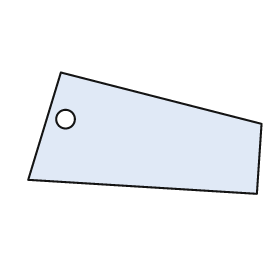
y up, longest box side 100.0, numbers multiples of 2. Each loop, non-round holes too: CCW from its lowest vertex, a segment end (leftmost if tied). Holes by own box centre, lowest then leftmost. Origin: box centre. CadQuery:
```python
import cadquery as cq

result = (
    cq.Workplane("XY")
    .moveTo(48.0, -26.0)
    .lineTo(50.0, 4.0)
    .lineTo(-36.0, 26.0)
    .lineTo(-50.0, -20.0)
    .close()
    .moveTo(-34.0, 6.0)
    .circle(4.0)
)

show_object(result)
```